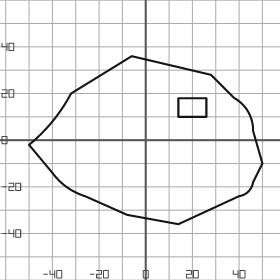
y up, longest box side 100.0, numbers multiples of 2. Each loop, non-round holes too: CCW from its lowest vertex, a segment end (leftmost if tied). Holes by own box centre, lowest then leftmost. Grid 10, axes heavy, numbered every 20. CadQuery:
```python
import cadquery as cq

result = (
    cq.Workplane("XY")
    .moveTo(14.0, -36.0)
    .lineTo(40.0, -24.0)
    .threePointArc((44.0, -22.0), (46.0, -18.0))
    .lineTo(50.0, -10.0)
    .lineTo(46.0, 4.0)
    .threePointArc((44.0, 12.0), (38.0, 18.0))
    .lineTo(28.0, 28.0)
    .lineTo(-6.0, 36.0)
    .lineTo(-32.0, 20.0)
    .threePointArc((-40.0, 8.0), (-50.0, -2.0))
    .lineTo(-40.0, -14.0)
    .threePointArc((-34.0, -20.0), (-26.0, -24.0))
    .lineTo(-8.0, -32.0)
    .close()
    .moveTo(14.0, 10.0)
    .lineTo(26.0, 10.0)
    .lineTo(26.0, 18.0)
    .lineTo(14.0, 18.0)
    .close()
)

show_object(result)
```